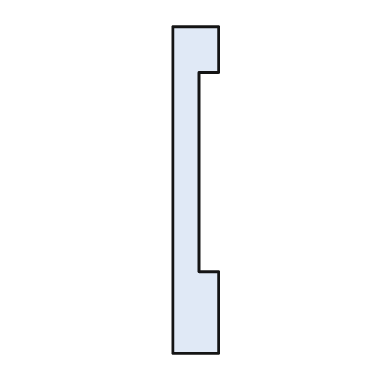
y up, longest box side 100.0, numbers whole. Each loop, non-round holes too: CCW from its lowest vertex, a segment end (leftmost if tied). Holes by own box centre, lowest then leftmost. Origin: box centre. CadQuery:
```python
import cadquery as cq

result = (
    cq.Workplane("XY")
    .moveTo(-7.0, -50.0)
    .lineTo(7.0, -50.0)
    .lineTo(7.0, -25.0)
    .lineTo(1.0, -25.0)
    .lineTo(1.0, 36.0)
    .lineTo(7.0, 36.0)
    .lineTo(7.0, 50.0)
    .lineTo(-7.0, 50.0)
    .close()
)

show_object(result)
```